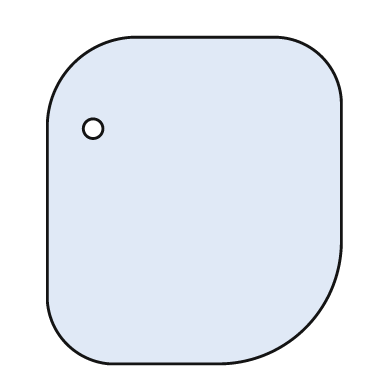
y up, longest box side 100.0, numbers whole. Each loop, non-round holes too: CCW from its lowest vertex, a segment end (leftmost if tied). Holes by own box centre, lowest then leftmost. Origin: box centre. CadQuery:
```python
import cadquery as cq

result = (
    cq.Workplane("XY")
    .moveTo(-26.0, -50.0)
    .lineTo(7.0, -50.0)
    .threePointArc((34.0, -39.0), (45.0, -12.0))
    .lineTo(45.0, 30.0)
    .threePointArc((39.0, 44.0), (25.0, 50.0))
    .lineTo(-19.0, 50.0)
    .threePointArc((-37.0, 42.0), (-45.0, 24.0))
    .lineTo(-45.0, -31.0)
    .threePointArc((-39.0, -44.0), (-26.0, -50.0))
    .close()
    .moveTo(-31.0, 22.0)
    .circle(3.0)
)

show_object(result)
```